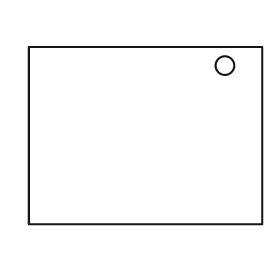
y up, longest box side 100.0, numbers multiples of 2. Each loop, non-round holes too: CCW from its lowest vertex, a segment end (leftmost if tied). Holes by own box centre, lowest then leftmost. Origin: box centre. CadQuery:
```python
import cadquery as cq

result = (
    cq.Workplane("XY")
    .moveTo(-50.0, -38.0)
    .lineTo(50.0, -38.0)
    .lineTo(50.0, 38.0)
    .lineTo(-50.0, 38.0)
    .close()
    .moveTo(34.0, 30.0)
    .circle(4.0)
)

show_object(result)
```